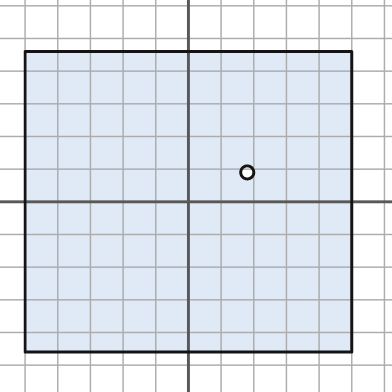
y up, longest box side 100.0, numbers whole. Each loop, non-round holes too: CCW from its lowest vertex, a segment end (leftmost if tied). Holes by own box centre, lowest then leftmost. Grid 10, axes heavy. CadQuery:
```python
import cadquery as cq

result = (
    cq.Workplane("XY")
    .moveTo(-50.0, -46.0)
    .lineTo(50.0, -46.0)
    .lineTo(50.0, 46.0)
    .lineTo(-50.0, 46.0)
    .close()
    .moveTo(18.0, 9.0)
    .circle(2.0)
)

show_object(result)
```